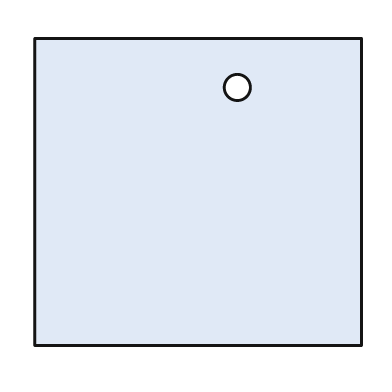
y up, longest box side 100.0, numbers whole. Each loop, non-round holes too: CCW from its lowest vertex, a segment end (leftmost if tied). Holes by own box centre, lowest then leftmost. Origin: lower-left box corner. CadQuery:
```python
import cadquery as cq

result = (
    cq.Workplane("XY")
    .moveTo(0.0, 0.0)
    .lineTo(100.0, 0.0)
    .lineTo(100.0, 94.0)
    .lineTo(0.0, 94.0)
    .close()
    .moveTo(62.0, 79.0)
    .circle(4.0)
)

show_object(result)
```